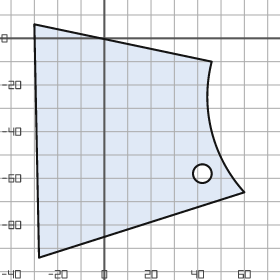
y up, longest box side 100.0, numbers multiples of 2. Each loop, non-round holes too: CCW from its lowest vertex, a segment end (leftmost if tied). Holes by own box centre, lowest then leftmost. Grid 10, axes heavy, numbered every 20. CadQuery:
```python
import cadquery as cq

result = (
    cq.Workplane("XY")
    .moveTo(-28.0, -94.0)
    .lineTo(60.0, -66.0)
    .threePointArc((46.0, -40.0), (46.0, -10.0))
    .lineTo(-30.0, 6.0)
    .close()
    .moveTo(42.0, -58.0)
    .circle(4.0)
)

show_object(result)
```